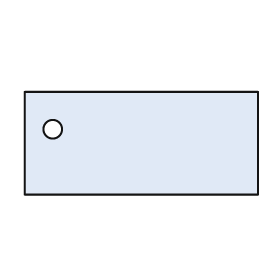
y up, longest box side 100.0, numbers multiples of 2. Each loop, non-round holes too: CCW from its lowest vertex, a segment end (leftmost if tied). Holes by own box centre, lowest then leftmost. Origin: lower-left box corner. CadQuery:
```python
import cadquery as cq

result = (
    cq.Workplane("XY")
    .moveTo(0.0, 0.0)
    .lineTo(100.0, 0.0)
    .lineTo(100.0, 44.0)
    .lineTo(0.0, 44.0)
    .close()
    .moveTo(12.0, 28.0)
    .circle(4.0)
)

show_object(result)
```